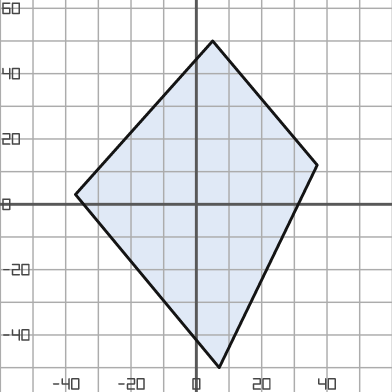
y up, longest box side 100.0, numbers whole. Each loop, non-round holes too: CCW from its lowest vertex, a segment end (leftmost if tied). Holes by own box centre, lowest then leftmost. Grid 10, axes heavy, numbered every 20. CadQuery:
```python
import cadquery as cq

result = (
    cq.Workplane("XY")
    .moveTo(7.0, -50.0)
    .lineTo(37.0, 12.0)
    .lineTo(5.0, 50.0)
    .lineTo(-37.0, 3.0)
    .close()
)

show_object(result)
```